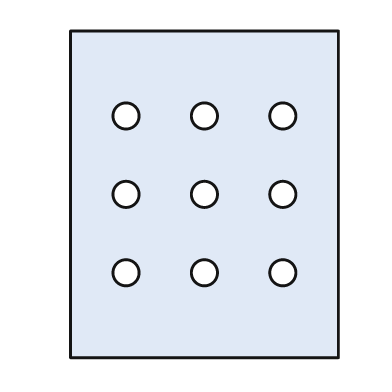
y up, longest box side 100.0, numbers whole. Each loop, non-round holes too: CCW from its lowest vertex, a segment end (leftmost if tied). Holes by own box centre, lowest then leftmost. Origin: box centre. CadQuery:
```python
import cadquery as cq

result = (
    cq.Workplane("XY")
    .moveTo(-41.0, -50.0)
    .lineTo(41.0, -50.0)
    .lineTo(41.0, 50.0)
    .lineTo(-41.0, 50.0)
    .close()
    .moveTo(-24.0, -24.0)
    .circle(4.0)
    .moveTo(0.0, -24.0)
    .circle(4.0)
    .moveTo(24.0, -24.0)
    .circle(4.0)
    .moveTo(-24.0, 0.0)
    .circle(4.0)
    .moveTo(0.0, 0.0)
    .circle(4.0)
    .moveTo(24.0, 0.0)
    .circle(4.0)
    .moveTo(-24.0, 24.0)
    .circle(4.0)
    .moveTo(0.0, 24.0)
    .circle(4.0)
    .moveTo(24.0, 24.0)
    .circle(4.0)
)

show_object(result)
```